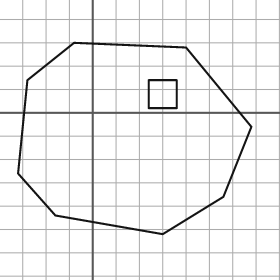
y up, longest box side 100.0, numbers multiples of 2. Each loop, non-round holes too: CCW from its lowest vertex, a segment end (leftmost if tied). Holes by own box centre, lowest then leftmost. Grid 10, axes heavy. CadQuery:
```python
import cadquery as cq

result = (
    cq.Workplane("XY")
    .moveTo(30.0, -52.0)
    .lineTo(56.0, -36.0)
    .lineTo(68.0, -6.0)
    .lineTo(40.0, 28.0)
    .lineTo(-8.0, 30.0)
    .lineTo(-28.0, 14.0)
    .lineTo(-32.0, -26.0)
    .lineTo(-16.0, -44.0)
    .close()
    .moveTo(24.0, 2.0)
    .lineTo(36.0, 2.0)
    .lineTo(36.0, 14.0)
    .lineTo(24.0, 14.0)
    .close()
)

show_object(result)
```